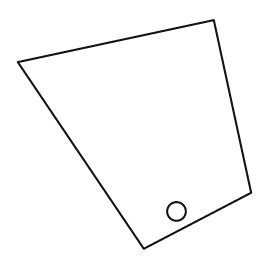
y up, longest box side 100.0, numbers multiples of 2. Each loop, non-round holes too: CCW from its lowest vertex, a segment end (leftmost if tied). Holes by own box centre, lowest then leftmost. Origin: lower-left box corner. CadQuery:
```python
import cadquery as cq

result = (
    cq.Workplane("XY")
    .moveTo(54.0, 0.0)
    .lineTo(100.0, 24.0)
    .lineTo(84.0, 98.0)
    .lineTo(0.0, 80.0)
    .close()
    .moveTo(68.0, 16.0)
    .circle(4.0)
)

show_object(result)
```